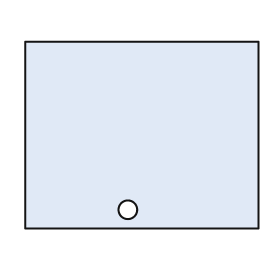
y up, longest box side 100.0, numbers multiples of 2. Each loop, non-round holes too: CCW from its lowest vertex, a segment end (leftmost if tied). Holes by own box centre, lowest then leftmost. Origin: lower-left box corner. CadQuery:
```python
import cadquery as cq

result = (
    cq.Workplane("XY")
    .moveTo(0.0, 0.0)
    .lineTo(100.0, 0.0)
    .lineTo(100.0, 80.0)
    .lineTo(0.0, 80.0)
    .close()
    .moveTo(44.0, 8.0)
    .circle(4.0)
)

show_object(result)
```